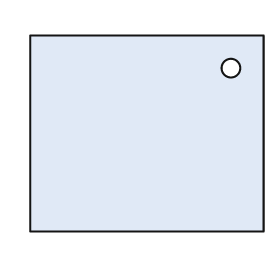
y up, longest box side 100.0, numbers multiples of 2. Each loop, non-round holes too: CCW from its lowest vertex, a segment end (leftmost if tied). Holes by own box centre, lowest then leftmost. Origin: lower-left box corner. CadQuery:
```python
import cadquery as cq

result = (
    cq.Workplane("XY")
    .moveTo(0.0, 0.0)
    .lineTo(100.0, 0.0)
    .lineTo(100.0, 84.0)
    .lineTo(0.0, 84.0)
    .close()
    .moveTo(86.0, 70.0)
    .circle(4.0)
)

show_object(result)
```